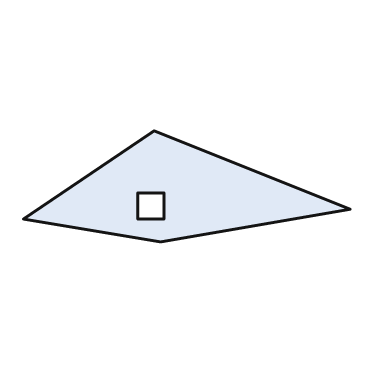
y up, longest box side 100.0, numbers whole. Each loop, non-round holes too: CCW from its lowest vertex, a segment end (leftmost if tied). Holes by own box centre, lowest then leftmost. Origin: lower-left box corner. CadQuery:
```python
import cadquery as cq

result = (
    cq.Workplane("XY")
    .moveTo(42.0, 0.0)
    .lineTo(100.0, 10.0)
    .lineTo(40.0, 34.0)
    .lineTo(0.0, 7.0)
    .close()
    .moveTo(35.0, 7.0)
    .lineTo(43.0, 7.0)
    .lineTo(43.0, 15.0)
    .lineTo(35.0, 15.0)
    .close()
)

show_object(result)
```